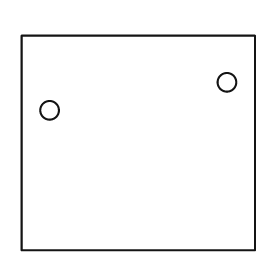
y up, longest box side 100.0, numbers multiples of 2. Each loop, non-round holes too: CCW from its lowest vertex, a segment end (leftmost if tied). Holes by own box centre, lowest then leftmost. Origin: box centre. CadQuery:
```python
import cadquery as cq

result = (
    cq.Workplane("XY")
    .moveTo(-50.0, -46.0)
    .lineTo(50.0, -46.0)
    .lineTo(50.0, 46.0)
    .lineTo(-50.0, 46.0)
    .close()
    .moveTo(-38.0, 14.0)
    .circle(4.0)
    .moveTo(38.0, 26.0)
    .circle(4.0)
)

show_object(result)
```